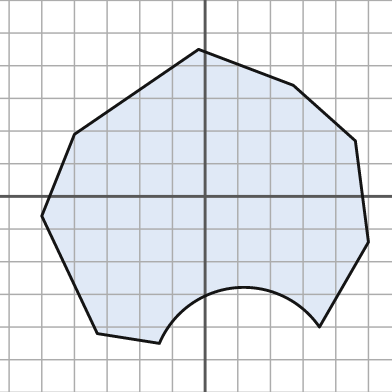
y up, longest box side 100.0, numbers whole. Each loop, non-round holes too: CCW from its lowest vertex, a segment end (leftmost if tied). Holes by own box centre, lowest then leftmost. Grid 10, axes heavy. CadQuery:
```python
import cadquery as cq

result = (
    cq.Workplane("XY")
    .moveTo(-14.0, -45.0)
    .threePointArc((9.0, -28.0), (35.0, -40.0))
    .lineTo(50.0, -14.0)
    .lineTo(46.0, 17.0)
    .lineTo(27.0, 34.0)
    .lineTo(-2.0, 45.0)
    .lineTo(-40.0, 19.0)
    .lineTo(-50.0, -6.0)
    .lineTo(-33.0, -42.0)
    .close()
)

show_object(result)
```